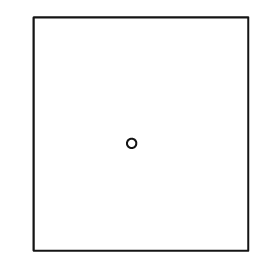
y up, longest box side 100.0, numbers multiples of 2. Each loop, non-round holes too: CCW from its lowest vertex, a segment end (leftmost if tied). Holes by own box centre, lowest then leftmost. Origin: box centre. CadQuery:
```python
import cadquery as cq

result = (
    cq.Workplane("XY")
    .moveTo(-46.0, -50.0)
    .lineTo(46.0, -50.0)
    .lineTo(46.0, 50.0)
    .lineTo(-46.0, 50.0)
    .close()
    .moveTo(-4.0, -4.0)
    .circle(2.0)
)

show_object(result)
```